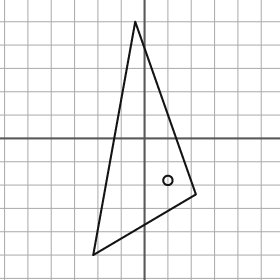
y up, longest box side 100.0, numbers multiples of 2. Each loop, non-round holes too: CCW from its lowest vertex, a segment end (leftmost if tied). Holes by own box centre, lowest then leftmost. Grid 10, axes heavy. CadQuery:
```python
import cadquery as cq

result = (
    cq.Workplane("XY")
    .moveTo(-22.0, -50.0)
    .lineTo(22.0, -24.0)
    .lineTo(-4.0, 50.0)
    .close()
    .moveTo(10.0, -18.0)
    .circle(2.0)
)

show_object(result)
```